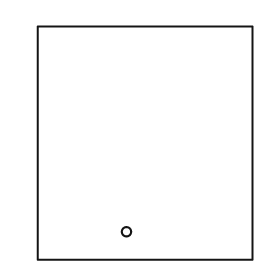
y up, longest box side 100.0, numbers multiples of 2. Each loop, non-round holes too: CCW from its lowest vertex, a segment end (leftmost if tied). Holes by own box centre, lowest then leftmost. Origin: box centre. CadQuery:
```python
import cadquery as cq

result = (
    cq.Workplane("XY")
    .moveTo(-46.0, -50.0)
    .lineTo(46.0, -50.0)
    .lineTo(46.0, 50.0)
    .lineTo(-46.0, 50.0)
    .close()
    .moveTo(-8.0, -38.0)
    .circle(2.0)
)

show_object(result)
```